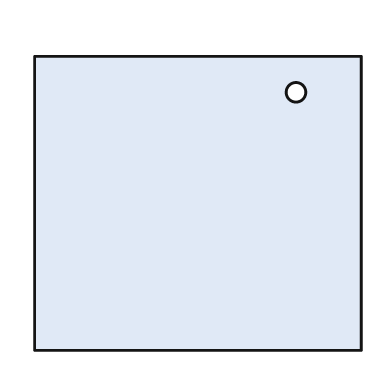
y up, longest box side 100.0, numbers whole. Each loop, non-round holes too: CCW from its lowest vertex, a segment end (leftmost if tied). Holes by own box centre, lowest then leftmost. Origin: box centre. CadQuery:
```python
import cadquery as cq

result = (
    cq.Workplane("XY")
    .moveTo(-50.0, -45.0)
    .lineTo(50.0, -45.0)
    .lineTo(50.0, 45.0)
    .lineTo(-50.0, 45.0)
    .close()
    .moveTo(30.0, 34.0)
    .circle(3.0)
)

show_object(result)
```